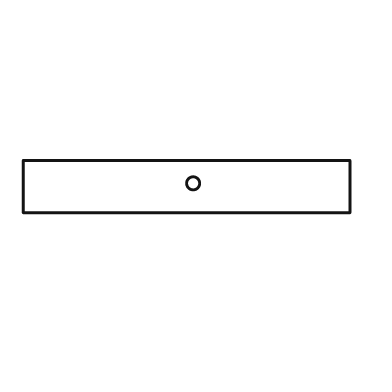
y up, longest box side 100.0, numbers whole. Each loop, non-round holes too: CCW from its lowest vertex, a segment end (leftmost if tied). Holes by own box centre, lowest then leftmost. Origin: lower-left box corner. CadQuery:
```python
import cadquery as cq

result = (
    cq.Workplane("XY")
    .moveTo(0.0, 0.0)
    .lineTo(100.0, 0.0)
    .lineTo(100.0, 16.0)
    .lineTo(0.0, 16.0)
    .close()
    .moveTo(52.0, 9.0)
    .circle(2.0)
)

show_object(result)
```